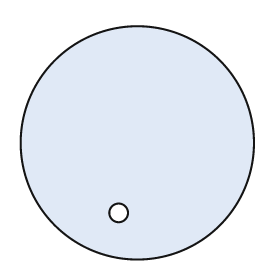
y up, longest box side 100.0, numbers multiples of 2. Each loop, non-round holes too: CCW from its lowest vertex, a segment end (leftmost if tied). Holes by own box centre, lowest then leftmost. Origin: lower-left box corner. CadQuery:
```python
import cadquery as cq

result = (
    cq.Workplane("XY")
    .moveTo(50.0, 50.0)
    .circle(50.0)
    .moveTo(42.0, 20.0)
    .circle(4.0)
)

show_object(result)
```